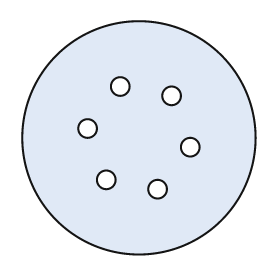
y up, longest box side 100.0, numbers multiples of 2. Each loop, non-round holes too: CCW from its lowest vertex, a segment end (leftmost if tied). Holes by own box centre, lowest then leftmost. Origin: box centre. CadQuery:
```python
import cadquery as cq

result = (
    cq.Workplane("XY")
    .moveTo(0.0, 0.0)
    .circle(50.0)
    .moveTo(8.0, -22.0)
    .circle(4.0)
    .moveTo(-14.0, -18.0)
    .circle(4.0)
    .moveTo(22.0, -4.0)
    .circle(4.0)
    .moveTo(-22.0, 4.0)
    .circle(4.0)
    .moveTo(14.0, 18.0)
    .circle(4.0)
    .moveTo(-8.0, 22.0)
    .circle(4.0)
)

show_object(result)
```